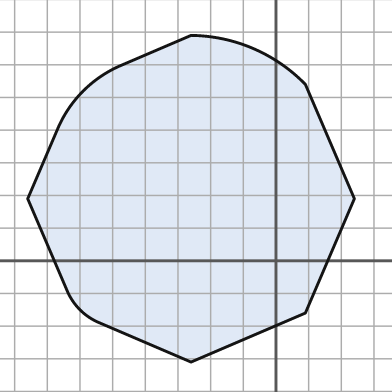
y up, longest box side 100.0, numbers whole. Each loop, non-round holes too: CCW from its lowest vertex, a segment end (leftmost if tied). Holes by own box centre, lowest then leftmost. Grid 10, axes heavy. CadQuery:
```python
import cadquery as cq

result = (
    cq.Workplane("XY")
    .moveTo(-26.0, -31.0)
    .lineTo(9.0, -16.0)
    .lineTo(24.0, 19.0)
    .lineTo(9.0, 54.0)
    .threePointArc((-7.0, 65.0), (-26.0, 69.0))
    .lineTo(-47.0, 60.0)
    .threePointArc((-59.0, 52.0), (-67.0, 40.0))
    .lineTo(-76.0, 19.0)
    .lineTo(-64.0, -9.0)
    .threePointArc((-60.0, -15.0), (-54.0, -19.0))
    .close()
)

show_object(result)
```